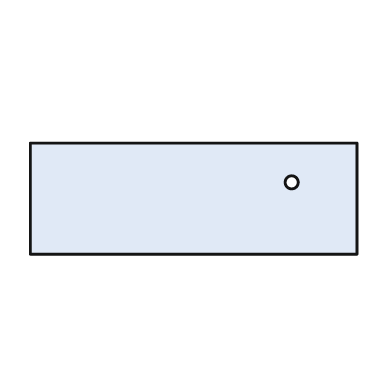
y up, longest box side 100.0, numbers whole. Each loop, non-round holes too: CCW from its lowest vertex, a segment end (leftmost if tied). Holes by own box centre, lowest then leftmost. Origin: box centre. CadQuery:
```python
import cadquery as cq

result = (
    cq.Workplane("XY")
    .moveTo(-50.0, -17.0)
    .lineTo(50.0, -17.0)
    .lineTo(50.0, 17.0)
    .lineTo(-50.0, 17.0)
    .close()
    .moveTo(30.0, 5.0)
    .circle(2.0)
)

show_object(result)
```